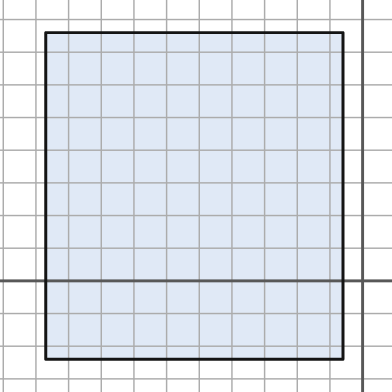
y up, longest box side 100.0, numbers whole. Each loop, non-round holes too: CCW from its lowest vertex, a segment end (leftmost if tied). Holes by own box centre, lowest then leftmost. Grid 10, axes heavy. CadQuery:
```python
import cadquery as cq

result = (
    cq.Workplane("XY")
    .moveTo(-97.0, -24.0)
    .lineTo(-6.0, -24.0)
    .lineTo(-6.0, 76.0)
    .lineTo(-97.0, 76.0)
    .close()
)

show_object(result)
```